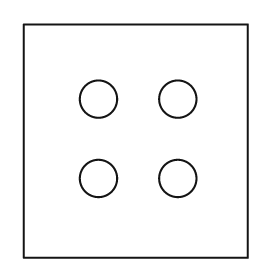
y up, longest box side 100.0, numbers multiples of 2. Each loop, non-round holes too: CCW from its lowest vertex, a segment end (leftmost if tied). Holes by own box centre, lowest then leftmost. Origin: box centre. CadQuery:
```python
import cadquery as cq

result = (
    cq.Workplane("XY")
    .moveTo(-48.0, -50.0)
    .lineTo(48.0, -50.0)
    .lineTo(48.0, 50.0)
    .lineTo(-48.0, 50.0)
    .close()
    .moveTo(-16.0, -16.0)
    .circle(8.0)
    .moveTo(18.0, -16.0)
    .circle(8.0)
    .moveTo(-16.0, 18.0)
    .circle(8.0)
    .moveTo(18.0, 18.0)
    .circle(8.0)
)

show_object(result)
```